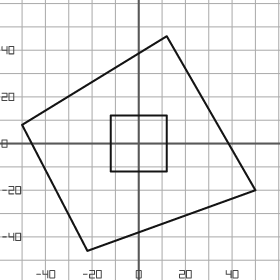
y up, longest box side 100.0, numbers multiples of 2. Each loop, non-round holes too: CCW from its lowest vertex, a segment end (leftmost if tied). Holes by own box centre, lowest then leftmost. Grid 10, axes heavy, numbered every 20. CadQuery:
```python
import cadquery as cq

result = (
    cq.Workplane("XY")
    .moveTo(-22.0, -46.0)
    .lineTo(50.0, -20.0)
    .lineTo(12.0, 46.0)
    .lineTo(-50.0, 8.0)
    .close()
    .moveTo(-12.0, -12.0)
    .lineTo(12.0, -12.0)
    .lineTo(12.0, 12.0)
    .lineTo(-12.0, 12.0)
    .close()
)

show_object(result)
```